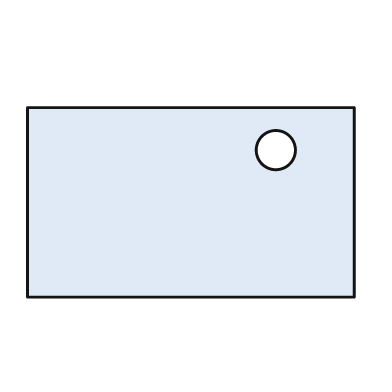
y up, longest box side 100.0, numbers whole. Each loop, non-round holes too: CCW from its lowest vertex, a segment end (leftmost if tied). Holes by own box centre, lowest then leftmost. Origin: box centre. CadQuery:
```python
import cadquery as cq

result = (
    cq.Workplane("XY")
    .moveTo(-50.0, -29.0)
    .lineTo(50.0, -29.0)
    .lineTo(50.0, 29.0)
    .lineTo(-50.0, 29.0)
    .close()
    .moveTo(26.0, 16.0)
    .circle(6.0)
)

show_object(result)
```